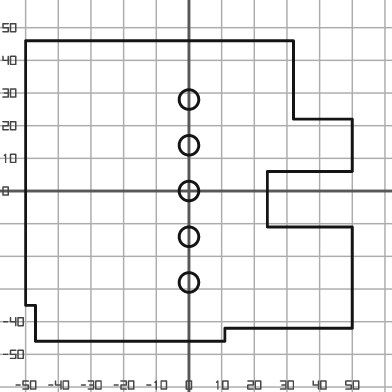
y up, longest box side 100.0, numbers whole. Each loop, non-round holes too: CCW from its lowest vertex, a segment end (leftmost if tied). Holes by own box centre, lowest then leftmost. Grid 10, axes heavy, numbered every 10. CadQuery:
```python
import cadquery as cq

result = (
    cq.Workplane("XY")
    .moveTo(-47.0, -46.0)
    .lineTo(11.0, -46.0)
    .lineTo(11.0, -42.0)
    .lineTo(50.0, -42.0)
    .lineTo(50.0, -11.0)
    .lineTo(24.0, -11.0)
    .lineTo(24.0, 6.0)
    .lineTo(50.0, 6.0)
    .lineTo(50.0, 22.0)
    .lineTo(32.0, 22.0)
    .lineTo(32.0, 46.0)
    .lineTo(-50.0, 46.0)
    .lineTo(-50.0, -35.0)
    .lineTo(-47.0, -35.0)
    .close()
    .moveTo(0.0, -28.0)
    .circle(3.0)
    .moveTo(0.0, -14.0)
    .circle(3.0)
    .moveTo(0.0, 0.0)
    .circle(3.0)
    .moveTo(0.0, 14.0)
    .circle(3.0)
    .moveTo(0.0, 28.0)
    .circle(3.0)
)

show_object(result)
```